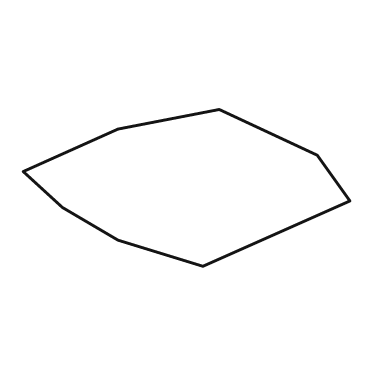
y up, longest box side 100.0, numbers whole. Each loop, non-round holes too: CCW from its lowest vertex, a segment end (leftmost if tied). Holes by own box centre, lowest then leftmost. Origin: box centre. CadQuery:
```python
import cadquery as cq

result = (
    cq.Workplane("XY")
    .moveTo(5.0, -24.0)
    .lineTo(50.0, -4.0)
    .lineTo(40.0, 10.0)
    .lineTo(10.0, 24.0)
    .lineTo(-21.0, 18.0)
    .lineTo(-50.0, 5.0)
    .lineTo(-38.0, -6.0)
    .lineTo(-21.0, -16.0)
    .close()
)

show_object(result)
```